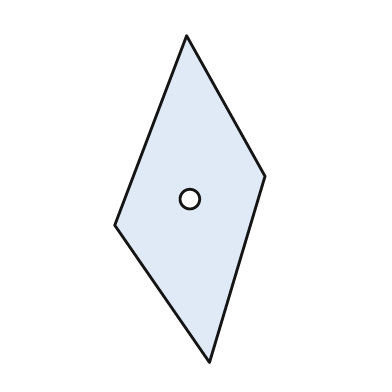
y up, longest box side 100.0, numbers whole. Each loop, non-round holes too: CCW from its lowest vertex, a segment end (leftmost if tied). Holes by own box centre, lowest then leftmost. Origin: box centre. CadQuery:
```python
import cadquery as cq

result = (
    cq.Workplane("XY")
    .moveTo(6.0, -50.0)
    .lineTo(23.0, 7.0)
    .lineTo(-1.0, 50.0)
    .lineTo(-23.0, -8.0)
    .close()
    .moveTo(0.0, 0.0)
    .circle(3.0)
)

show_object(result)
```